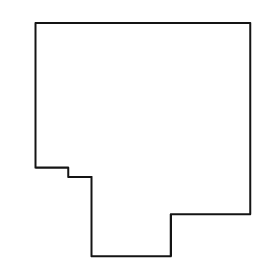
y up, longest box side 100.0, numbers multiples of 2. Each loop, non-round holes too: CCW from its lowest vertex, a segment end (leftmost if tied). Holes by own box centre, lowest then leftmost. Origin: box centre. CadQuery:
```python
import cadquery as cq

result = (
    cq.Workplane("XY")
    .moveTo(-22.0, -50.0)
    .lineTo(12.0, -50.0)
    .lineTo(12.0, -32.0)
    .lineTo(46.0, -32.0)
    .lineTo(46.0, 50.0)
    .lineTo(-46.0, 50.0)
    .lineTo(-46.0, -12.0)
    .lineTo(-32.0, -12.0)
    .lineTo(-32.0, -16.0)
    .lineTo(-22.0, -16.0)
    .close()
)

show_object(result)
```